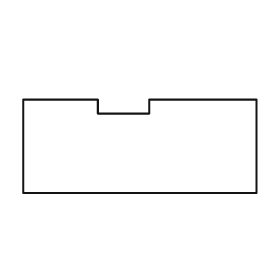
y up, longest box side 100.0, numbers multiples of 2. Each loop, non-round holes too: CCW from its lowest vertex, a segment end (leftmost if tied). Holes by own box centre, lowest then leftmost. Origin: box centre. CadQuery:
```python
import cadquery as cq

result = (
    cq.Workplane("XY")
    .moveTo(-50.0, -20.0)
    .lineTo(50.0, -20.0)
    .lineTo(50.0, 20.0)
    .lineTo(4.0, 20.0)
    .lineTo(4.0, 14.0)
    .lineTo(-18.0, 14.0)
    .lineTo(-18.0, 20.0)
    .lineTo(-50.0, 20.0)
    .close()
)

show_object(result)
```